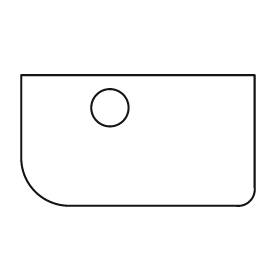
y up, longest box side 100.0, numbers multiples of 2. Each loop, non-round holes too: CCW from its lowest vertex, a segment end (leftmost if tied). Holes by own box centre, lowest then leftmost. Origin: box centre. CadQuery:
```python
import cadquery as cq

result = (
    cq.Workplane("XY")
    .moveTo(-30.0, -28.0)
    .lineTo(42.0, -28.0)
    .threePointArc((48.0, -26.0), (50.0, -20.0))
    .lineTo(50.0, 28.0)
    .lineTo(-50.0, 28.0)
    .lineTo(-50.0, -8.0)
    .threePointArc((-44.0, -22.0), (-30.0, -28.0))
    .close()
    .moveTo(-12.0, 14.0)
    .circle(8.0)
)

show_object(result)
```